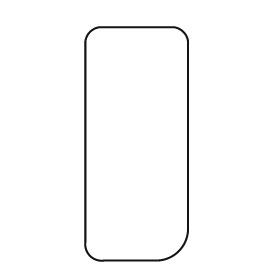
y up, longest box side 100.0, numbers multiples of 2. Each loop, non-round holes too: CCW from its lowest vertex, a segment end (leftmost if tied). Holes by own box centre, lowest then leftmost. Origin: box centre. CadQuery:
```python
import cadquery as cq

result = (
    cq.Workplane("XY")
    .moveTo(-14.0, -50.0)
    .lineTo(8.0, -50.0)
    .threePointArc((18.0, -46.0), (22.0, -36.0))
    .lineTo(22.0, 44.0)
    .threePointArc((20.0, 48.0), (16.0, 50.0))
    .lineTo(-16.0, 50.0)
    .threePointArc((-20.0, 48.0), (-22.0, 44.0))
    .lineTo(-22.0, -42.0)
    .threePointArc((-20.0, -48.0), (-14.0, -50.0))
    .close()
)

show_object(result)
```